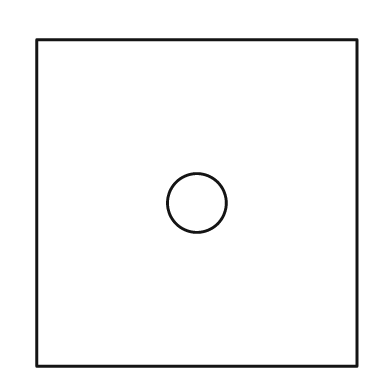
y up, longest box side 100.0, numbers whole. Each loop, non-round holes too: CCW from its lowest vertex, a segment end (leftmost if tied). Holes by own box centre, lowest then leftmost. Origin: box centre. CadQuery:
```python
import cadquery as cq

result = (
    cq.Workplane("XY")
    .moveTo(-49.0, -50.0)
    .lineTo(49.0, -50.0)
    .lineTo(49.0, 50.0)
    .lineTo(-49.0, 50.0)
    .close()
    .moveTo(0.0, 0.0)
    .circle(9.0)
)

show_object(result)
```